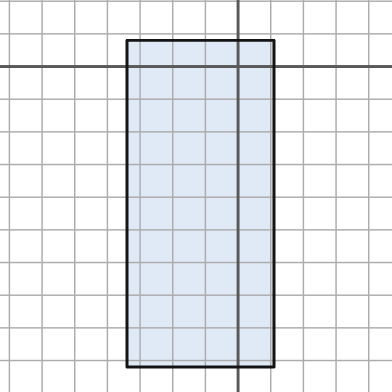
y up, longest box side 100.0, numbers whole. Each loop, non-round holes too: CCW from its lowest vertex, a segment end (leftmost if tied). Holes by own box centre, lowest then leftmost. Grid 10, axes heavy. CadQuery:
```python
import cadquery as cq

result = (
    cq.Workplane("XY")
    .moveTo(-34.0, -92.0)
    .lineTo(11.0, -92.0)
    .lineTo(11.0, 8.0)
    .lineTo(-34.0, 8.0)
    .close()
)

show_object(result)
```